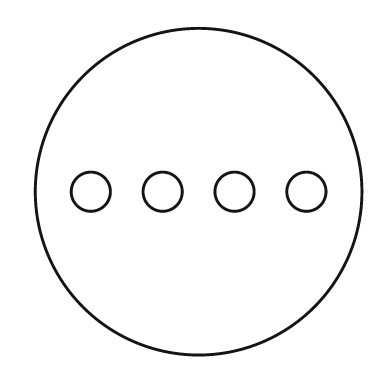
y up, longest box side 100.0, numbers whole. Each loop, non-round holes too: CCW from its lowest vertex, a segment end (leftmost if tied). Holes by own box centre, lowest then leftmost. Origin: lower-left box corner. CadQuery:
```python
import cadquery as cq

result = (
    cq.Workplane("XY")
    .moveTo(50.0, 50.0)
    .circle(50.0)
    .moveTo(17.0, 50.0)
    .circle(6.0)
    .moveTo(39.0, 50.0)
    .circle(6.0)
    .moveTo(61.0, 50.0)
    .circle(6.0)
    .moveTo(83.0, 50.0)
    .circle(6.0)
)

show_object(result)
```